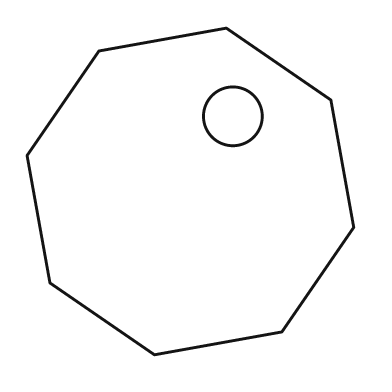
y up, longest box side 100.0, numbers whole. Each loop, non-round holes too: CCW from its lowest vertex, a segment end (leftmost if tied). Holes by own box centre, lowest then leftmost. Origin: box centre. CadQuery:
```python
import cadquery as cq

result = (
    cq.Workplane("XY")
    .moveTo(-11.0, -50.0)
    .lineTo(28.0, -43.0)
    .lineTo(50.0, -11.0)
    .lineTo(43.0, 28.0)
    .lineTo(11.0, 50.0)
    .lineTo(-28.0, 43.0)
    .lineTo(-50.0, 11.0)
    .lineTo(-43.0, -28.0)
    .close()
    .moveTo(13.0, 23.0)
    .circle(9.0)
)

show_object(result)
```